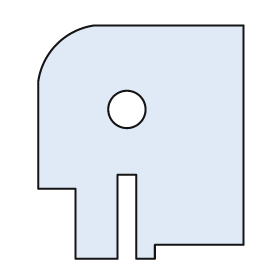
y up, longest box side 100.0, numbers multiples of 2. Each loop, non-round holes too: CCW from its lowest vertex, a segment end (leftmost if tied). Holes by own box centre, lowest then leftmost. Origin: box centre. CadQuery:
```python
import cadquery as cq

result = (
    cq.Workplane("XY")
    .moveTo(-28.0, -50.0)
    .lineTo(-10.0, -50.0)
    .lineTo(-10.0, -14.0)
    .lineTo(-2.0, -14.0)
    .lineTo(-2.0, -50.0)
    .lineTo(6.0, -50.0)
    .lineTo(6.0, -44.0)
    .lineTo(44.0, -44.0)
    .lineTo(44.0, 50.0)
    .lineTo(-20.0, 50.0)
    .threePointArc((-36.0, 42.0), (-44.0, 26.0))
    .lineTo(-44.0, -20.0)
    .lineTo(-28.0, -20.0)
    .close()
    .moveTo(-6.0, 14.0)
    .circle(8.0)
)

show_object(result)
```